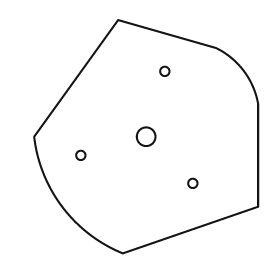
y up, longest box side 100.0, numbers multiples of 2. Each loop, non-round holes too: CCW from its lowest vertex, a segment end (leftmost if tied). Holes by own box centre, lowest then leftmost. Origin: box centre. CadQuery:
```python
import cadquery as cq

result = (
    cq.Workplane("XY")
    .moveTo(-10.0, -50.0)
    .lineTo(48.0, -30.0)
    .lineTo(48.0, 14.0)
    .threePointArc((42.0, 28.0), (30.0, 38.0))
    .lineTo(-12.0, 50.0)
    .lineTo(-48.0, 0.0)
    .threePointArc((-36.0, -30.0), (-10.0, -50.0))
    .close()
    .moveTo(20.0, -20.0)
    .circle(2.0)
    .moveTo(-28.0, -8.0)
    .circle(2.0)
    .moveTo(0.0, 0.0)
    .circle(4.0)
    .moveTo(8.0, 28.0)
    .circle(2.0)
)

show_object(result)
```